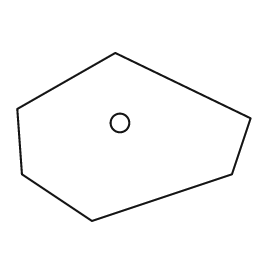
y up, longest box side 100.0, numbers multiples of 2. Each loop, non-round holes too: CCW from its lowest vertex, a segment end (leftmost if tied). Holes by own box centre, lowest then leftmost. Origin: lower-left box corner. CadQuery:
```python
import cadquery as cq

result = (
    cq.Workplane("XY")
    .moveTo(32.0, 0.0)
    .lineTo(92.0, 20.0)
    .lineTo(100.0, 44.0)
    .lineTo(42.0, 72.0)
    .lineTo(0.0, 48.0)
    .lineTo(2.0, 20.0)
    .close()
    .moveTo(44.0, 42.0)
    .circle(4.0)
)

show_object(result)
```